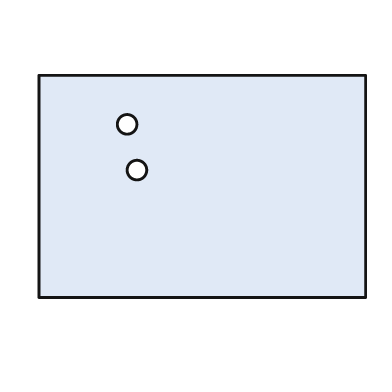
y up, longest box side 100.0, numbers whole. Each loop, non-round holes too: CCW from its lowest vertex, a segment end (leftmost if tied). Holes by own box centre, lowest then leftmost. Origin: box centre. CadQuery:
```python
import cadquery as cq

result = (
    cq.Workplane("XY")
    .moveTo(-50.0, -34.0)
    .lineTo(50.0, -34.0)
    .lineTo(50.0, 34.0)
    .lineTo(-50.0, 34.0)
    .close()
    .moveTo(-20.0, 5.0)
    .circle(3.0)
    .moveTo(-23.0, 19.0)
    .circle(3.0)
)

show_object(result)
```